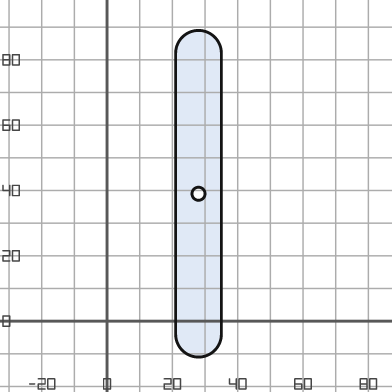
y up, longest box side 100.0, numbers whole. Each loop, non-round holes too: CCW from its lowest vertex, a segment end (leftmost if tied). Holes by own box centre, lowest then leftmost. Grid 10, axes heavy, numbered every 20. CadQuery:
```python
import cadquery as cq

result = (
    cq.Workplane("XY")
    .moveTo(21.0, -4.0)
    .threePointArc((28.0, -11.0), (35.0, -4.0))
    .lineTo(35.0, 82.0)
    .threePointArc((28.0, 89.0), (21.0, 82.0))
    .close()
    .moveTo(28.0, 39.0)
    .circle(2.0)
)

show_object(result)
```